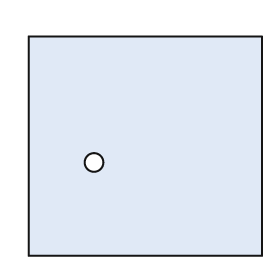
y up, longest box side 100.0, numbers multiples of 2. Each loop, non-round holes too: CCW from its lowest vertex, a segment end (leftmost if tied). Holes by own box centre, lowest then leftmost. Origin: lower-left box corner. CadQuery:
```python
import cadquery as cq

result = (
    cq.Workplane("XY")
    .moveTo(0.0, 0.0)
    .lineTo(100.0, 0.0)
    .lineTo(100.0, 94.0)
    .lineTo(0.0, 94.0)
    .close()
    .moveTo(28.0, 40.0)
    .circle(4.0)
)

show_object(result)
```